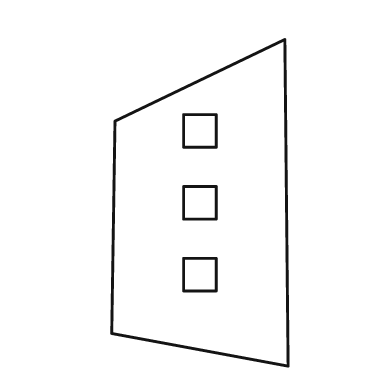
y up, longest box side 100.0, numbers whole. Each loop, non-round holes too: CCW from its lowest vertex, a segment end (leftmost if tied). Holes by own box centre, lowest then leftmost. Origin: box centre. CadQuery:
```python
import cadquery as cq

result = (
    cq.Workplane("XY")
    .moveTo(27.0, -50.0)
    .lineTo(26.0, 50.0)
    .lineTo(-26.0, 25.0)
    .lineTo(-27.0, -40.0)
    .close()
    .moveTo(-5.0, -27.0)
    .lineTo(5.0, -27.0)
    .lineTo(5.0, -17.0)
    .lineTo(-5.0, -17.0)
    .close()
    .moveTo(-5.0, -5.0)
    .lineTo(5.0, -5.0)
    .lineTo(5.0, 5.0)
    .lineTo(-5.0, 5.0)
    .close()
    .moveTo(-5.0, 17.0)
    .lineTo(5.0, 17.0)
    .lineTo(5.0, 27.0)
    .lineTo(-5.0, 27.0)
    .close()
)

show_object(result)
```